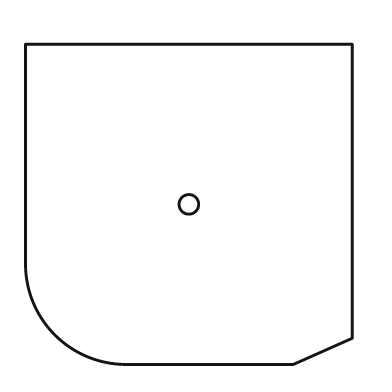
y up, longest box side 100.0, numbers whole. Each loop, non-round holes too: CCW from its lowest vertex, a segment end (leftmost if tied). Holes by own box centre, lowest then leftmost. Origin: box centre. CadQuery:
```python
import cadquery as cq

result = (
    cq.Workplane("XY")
    .moveTo(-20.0, -49.0)
    .lineTo(32.0, -49.0)
    .lineTo(50.0, -41.0)
    .lineTo(50.0, 49.0)
    .lineTo(-50.0, 49.0)
    .lineTo(-50.0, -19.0)
    .threePointArc((-41.0, -40.0), (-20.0, -49.0))
    .close()
    .moveTo(0.0, 0.0)
    .circle(3.0)
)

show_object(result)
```